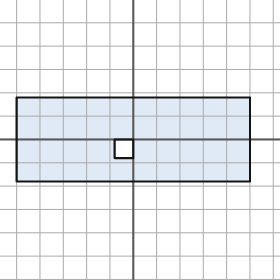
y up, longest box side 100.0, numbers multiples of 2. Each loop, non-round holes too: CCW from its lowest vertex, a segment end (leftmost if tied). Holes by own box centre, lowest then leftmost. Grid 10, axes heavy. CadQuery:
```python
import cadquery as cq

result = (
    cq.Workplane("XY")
    .moveTo(-50.0, -18.0)
    .lineTo(50.0, -18.0)
    .lineTo(50.0, 18.0)
    .lineTo(-50.0, 18.0)
    .close()
    .moveTo(-8.0, -8.0)
    .lineTo(0.0, -8.0)
    .lineTo(0.0, 0.0)
    .lineTo(-8.0, 0.0)
    .close()
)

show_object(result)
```